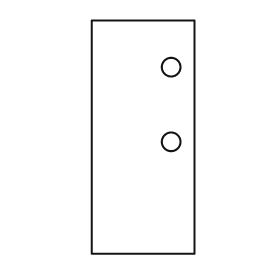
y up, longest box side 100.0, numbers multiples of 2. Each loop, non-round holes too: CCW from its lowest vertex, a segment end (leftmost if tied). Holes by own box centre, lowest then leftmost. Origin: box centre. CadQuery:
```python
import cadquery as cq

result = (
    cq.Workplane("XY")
    .moveTo(-22.0, -50.0)
    .lineTo(22.0, -50.0)
    .lineTo(22.0, 50.0)
    .lineTo(-22.0, 50.0)
    .close()
    .moveTo(12.0, -2.0)
    .circle(4.0)
    .moveTo(12.0, 30.0)
    .circle(4.0)
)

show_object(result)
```